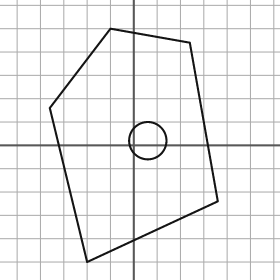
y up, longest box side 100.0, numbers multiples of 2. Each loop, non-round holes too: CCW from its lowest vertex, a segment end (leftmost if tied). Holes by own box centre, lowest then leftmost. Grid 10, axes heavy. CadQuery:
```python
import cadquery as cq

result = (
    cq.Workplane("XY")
    .moveTo(-20.0, -50.0)
    .lineTo(36.0, -24.0)
    .lineTo(24.0, 44.0)
    .lineTo(-10.0, 50.0)
    .lineTo(-36.0, 16.0)
    .close()
    .moveTo(6.0, 2.0)
    .circle(8.0)
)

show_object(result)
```